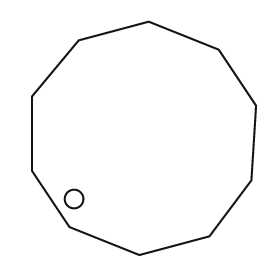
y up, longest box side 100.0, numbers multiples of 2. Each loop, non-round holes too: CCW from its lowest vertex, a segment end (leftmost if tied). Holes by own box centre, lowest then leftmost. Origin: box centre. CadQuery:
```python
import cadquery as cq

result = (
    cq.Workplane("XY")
    .moveTo(-2.0, -50.0)
    .lineTo(28.0, -42.0)
    .lineTo(46.0, -18.0)
    .lineTo(48.0, 14.0)
    .lineTo(32.0, 38.0)
    .lineTo(2.0, 50.0)
    .lineTo(-28.0, 42.0)
    .lineTo(-48.0, 18.0)
    .lineTo(-48.0, -14.0)
    .lineTo(-32.0, -38.0)
    .close()
    .moveTo(-30.0, -26.0)
    .circle(4.0)
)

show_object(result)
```